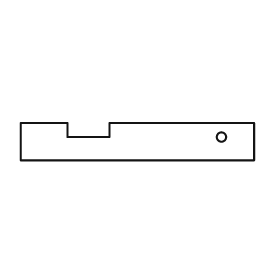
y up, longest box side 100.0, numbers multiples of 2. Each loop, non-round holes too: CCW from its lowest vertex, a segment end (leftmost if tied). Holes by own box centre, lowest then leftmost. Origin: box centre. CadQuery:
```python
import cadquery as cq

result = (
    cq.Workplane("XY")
    .moveTo(-50.0, -8.0)
    .lineTo(50.0, -8.0)
    .lineTo(50.0, 8.0)
    .lineTo(-12.0, 8.0)
    .lineTo(-12.0, 2.0)
    .lineTo(-30.0, 2.0)
    .lineTo(-30.0, 8.0)
    .lineTo(-50.0, 8.0)
    .close()
    .moveTo(36.0, 2.0)
    .circle(2.0)
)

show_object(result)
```